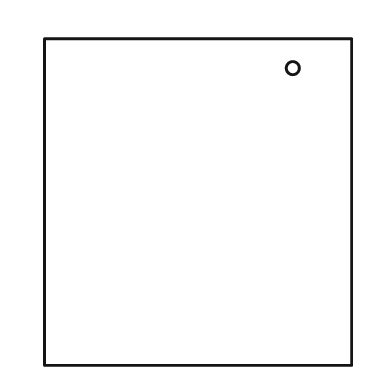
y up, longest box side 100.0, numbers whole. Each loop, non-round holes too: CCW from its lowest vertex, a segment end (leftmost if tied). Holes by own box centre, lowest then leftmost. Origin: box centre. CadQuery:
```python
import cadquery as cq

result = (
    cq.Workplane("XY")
    .moveTo(-47.0, -50.0)
    .lineTo(47.0, -50.0)
    .lineTo(47.0, 50.0)
    .lineTo(-47.0, 50.0)
    .close()
    .moveTo(29.0, 41.0)
    .circle(2.0)
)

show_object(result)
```